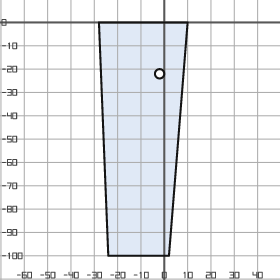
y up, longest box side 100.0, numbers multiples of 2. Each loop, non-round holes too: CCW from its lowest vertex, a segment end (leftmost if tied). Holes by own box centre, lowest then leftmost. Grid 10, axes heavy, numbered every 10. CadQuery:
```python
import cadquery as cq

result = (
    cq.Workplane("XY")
    .moveTo(-24.0, -100.0)
    .lineTo(2.0, -100.0)
    .lineTo(10.0, 0.0)
    .lineTo(-28.0, 0.0)
    .close()
    .moveTo(-2.0, -22.0)
    .circle(2.0)
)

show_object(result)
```